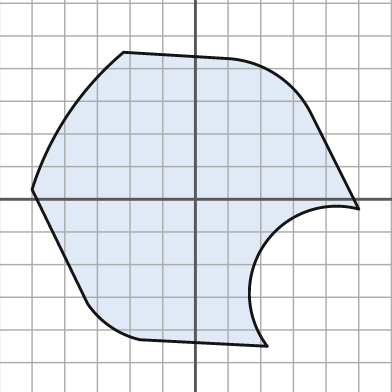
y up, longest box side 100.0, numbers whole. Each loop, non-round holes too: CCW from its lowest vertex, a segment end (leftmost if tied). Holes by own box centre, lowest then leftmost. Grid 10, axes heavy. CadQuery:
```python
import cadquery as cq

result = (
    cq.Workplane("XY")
    .moveTo(22.0, -45.0)
    .threePointArc((21.0, -14.0), (50.0, -3.0))
    .lineTo(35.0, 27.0)
    .threePointArc((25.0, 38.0), (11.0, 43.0))
    .lineTo(-22.0, 45.0)
    .threePointArc((-39.0, 26.0), (-50.0, 3.0))
    .lineTo(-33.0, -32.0)
    .threePointArc((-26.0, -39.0), (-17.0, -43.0))
    .close()
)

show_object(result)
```